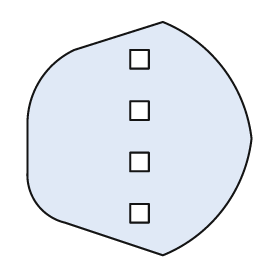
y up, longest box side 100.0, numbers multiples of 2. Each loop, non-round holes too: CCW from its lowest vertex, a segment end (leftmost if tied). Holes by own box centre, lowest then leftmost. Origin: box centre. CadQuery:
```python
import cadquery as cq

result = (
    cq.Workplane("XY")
    .moveTo(10.0, -50.0)
    .threePointArc((36.0, -30.0), (48.0, 0.0))
    .threePointArc((36.0, 30.0), (10.0, 50.0))
    .lineTo(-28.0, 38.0)
    .threePointArc((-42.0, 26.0), (-48.0, 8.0))
    .lineTo(-48.0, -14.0)
    .threePointArc((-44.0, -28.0), (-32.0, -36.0))
    .close()
    .moveTo(-4.0, -36.0)
    .lineTo(4.0, -36.0)
    .lineTo(4.0, -28.0)
    .lineTo(-4.0, -28.0)
    .close()
    .moveTo(-4.0, -14.0)
    .lineTo(4.0, -14.0)
    .lineTo(4.0, -6.0)
    .lineTo(-4.0, -6.0)
    .close()
    .moveTo(-4.0, 8.0)
    .lineTo(4.0, 8.0)
    .lineTo(4.0, 16.0)
    .lineTo(-4.0, 16.0)
    .close()
    .moveTo(-4.0, 30.0)
    .lineTo(4.0, 30.0)
    .lineTo(4.0, 38.0)
    .lineTo(-4.0, 38.0)
    .close()
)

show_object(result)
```